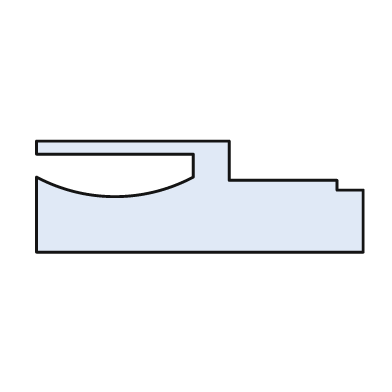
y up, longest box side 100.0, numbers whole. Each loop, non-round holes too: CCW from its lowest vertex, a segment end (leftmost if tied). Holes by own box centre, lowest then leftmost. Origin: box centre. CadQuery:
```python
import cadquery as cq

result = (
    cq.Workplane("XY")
    .moveTo(-50.0, -17.0)
    .lineTo(50.0, -17.0)
    .lineTo(50.0, 2.0)
    .lineTo(42.0, 2.0)
    .lineTo(42.0, 5.0)
    .lineTo(9.0, 5.0)
    .lineTo(9.0, 17.0)
    .lineTo(-50.0, 17.0)
    .lineTo(-50.0, 13.0)
    .lineTo(-2.0, 13.0)
    .lineTo(-2.0, 6.0)
    .threePointArc((-26.0, 0.0), (-50.0, 6.0))
    .close()
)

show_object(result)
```